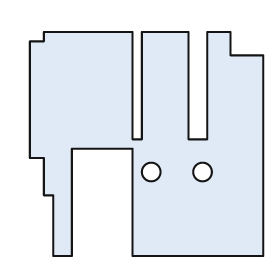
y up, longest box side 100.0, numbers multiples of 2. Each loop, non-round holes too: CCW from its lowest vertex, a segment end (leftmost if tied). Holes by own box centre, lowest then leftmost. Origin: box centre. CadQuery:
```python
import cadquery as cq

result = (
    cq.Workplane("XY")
    .moveTo(-40.0, -48.0)
    .lineTo(-32.0, -48.0)
    .lineTo(-32.0, -2.0)
    .lineTo(-6.0, -2.0)
    .lineTo(-6.0, -48.0)
    .lineTo(50.0, -48.0)
    .lineTo(50.0, 38.0)
    .lineTo(36.0, 38.0)
    .lineTo(36.0, 48.0)
    .lineTo(26.0, 48.0)
    .lineTo(26.0, 2.0)
    .lineTo(18.0, 2.0)
    .lineTo(18.0, 48.0)
    .lineTo(-2.0, 48.0)
    .lineTo(-2.0, 2.0)
    .lineTo(-6.0, 2.0)
    .lineTo(-6.0, 48.0)
    .lineTo(-44.0, 48.0)
    .lineTo(-44.0, 44.0)
    .lineTo(-50.0, 44.0)
    .lineTo(-50.0, -6.0)
    .lineTo(-44.0, -6.0)
    .lineTo(-44.0, -22.0)
    .lineTo(-40.0, -22.0)
    .close()
    .moveTo(2.0, -12.0)
    .circle(4.0)
    .moveTo(24.0, -12.0)
    .circle(4.0)
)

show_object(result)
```